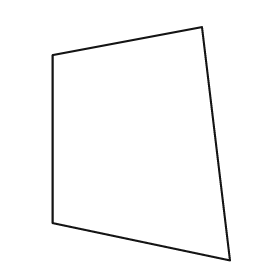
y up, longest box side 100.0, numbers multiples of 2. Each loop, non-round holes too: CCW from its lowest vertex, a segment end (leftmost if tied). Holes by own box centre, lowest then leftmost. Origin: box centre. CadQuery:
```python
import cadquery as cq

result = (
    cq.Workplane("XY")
    .moveTo(38.0, -50.0)
    .lineTo(26.0, 50.0)
    .lineTo(-38.0, 38.0)
    .lineTo(-38.0, -34.0)
    .close()
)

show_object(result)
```